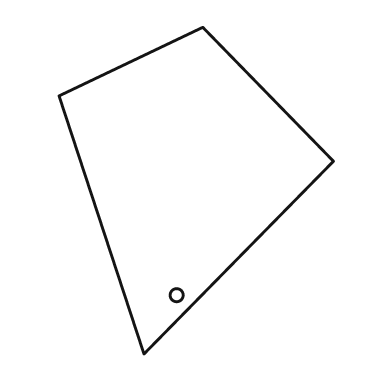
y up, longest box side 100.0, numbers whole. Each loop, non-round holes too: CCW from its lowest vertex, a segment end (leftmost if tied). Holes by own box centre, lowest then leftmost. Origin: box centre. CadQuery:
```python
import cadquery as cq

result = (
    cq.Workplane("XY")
    .moveTo(-16.0, -50.0)
    .lineTo(42.0, 9.0)
    .lineTo(2.0, 50.0)
    .lineTo(-42.0, 29.0)
    .close()
    .moveTo(-6.0, -32.0)
    .circle(2.0)
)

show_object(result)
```